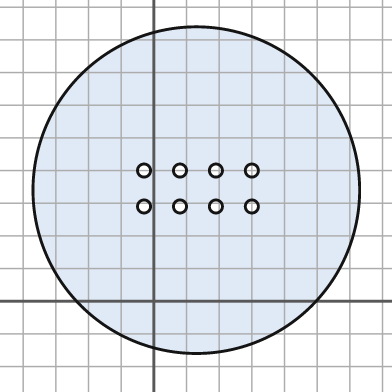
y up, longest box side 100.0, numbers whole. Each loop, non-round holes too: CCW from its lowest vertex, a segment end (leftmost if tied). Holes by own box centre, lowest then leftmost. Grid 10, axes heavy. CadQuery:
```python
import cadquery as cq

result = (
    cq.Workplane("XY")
    .moveTo(13.0, 34.0)
    .circle(50.0)
    .moveTo(-3.0, 29.0)
    .circle(2.0)
    .moveTo(8.0, 29.0)
    .circle(2.0)
    .moveTo(19.0, 29.0)
    .circle(2.0)
    .moveTo(30.0, 29.0)
    .circle(2.0)
    .moveTo(-3.0, 40.0)
    .circle(2.0)
    .moveTo(8.0, 40.0)
    .circle(2.0)
    .moveTo(19.0, 40.0)
    .circle(2.0)
    .moveTo(30.0, 40.0)
    .circle(2.0)
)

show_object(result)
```